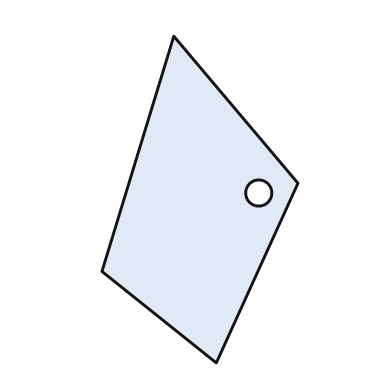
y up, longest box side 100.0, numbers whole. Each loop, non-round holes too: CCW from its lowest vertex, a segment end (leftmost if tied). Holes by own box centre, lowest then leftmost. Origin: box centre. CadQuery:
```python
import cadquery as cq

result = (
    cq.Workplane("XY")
    .moveTo(5.0, -50.0)
    .lineTo(30.0, 5.0)
    .lineTo(-8.0, 50.0)
    .lineTo(-30.0, -22.0)
    .close()
    .moveTo(18.0, 2.0)
    .circle(4.0)
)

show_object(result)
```